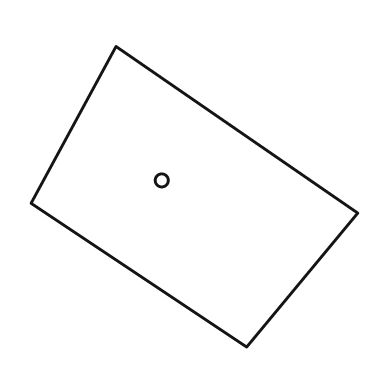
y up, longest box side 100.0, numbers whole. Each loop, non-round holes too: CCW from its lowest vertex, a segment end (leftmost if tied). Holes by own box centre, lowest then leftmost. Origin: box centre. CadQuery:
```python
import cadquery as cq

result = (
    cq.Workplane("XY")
    .moveTo(16.0, -46.0)
    .lineTo(50.0, -5.0)
    .lineTo(-24.0, 46.0)
    .lineTo(-50.0, -2.0)
    .close()
    .moveTo(-10.0, 5.0)
    .circle(2.0)
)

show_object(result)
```